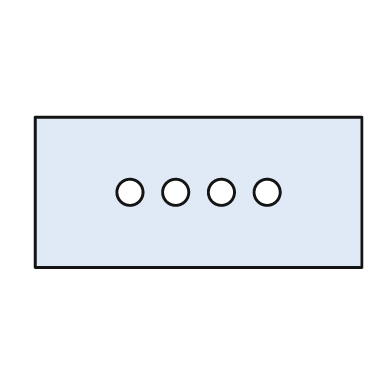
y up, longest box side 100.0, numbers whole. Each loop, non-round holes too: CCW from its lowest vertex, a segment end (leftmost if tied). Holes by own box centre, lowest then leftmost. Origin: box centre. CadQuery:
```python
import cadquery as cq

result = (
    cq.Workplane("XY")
    .moveTo(-50.0, -23.0)
    .lineTo(50.0, -23.0)
    .lineTo(50.0, 23.0)
    .lineTo(-50.0, 23.0)
    .close()
    .moveTo(-21.0, 0.0)
    .circle(4.0)
    .moveTo(-7.0, 0.0)
    .circle(4.0)
    .moveTo(7.0, 0.0)
    .circle(4.0)
    .moveTo(21.0, 0.0)
    .circle(4.0)
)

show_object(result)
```